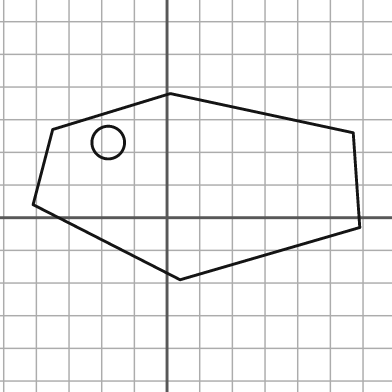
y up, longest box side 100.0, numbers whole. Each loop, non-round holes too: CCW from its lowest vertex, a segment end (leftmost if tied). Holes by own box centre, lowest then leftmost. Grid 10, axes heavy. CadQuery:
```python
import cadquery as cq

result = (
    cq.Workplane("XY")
    .moveTo(4.0, -19.0)
    .lineTo(59.0, -3.0)
    .lineTo(57.0, 26.0)
    .lineTo(1.0, 38.0)
    .lineTo(-35.0, 27.0)
    .lineTo(-41.0, 4.0)
    .close()
    .moveTo(-18.0, 23.0)
    .circle(5.0)
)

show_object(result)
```